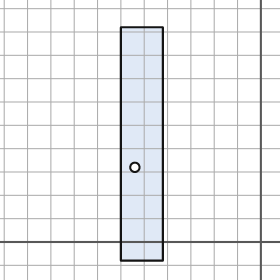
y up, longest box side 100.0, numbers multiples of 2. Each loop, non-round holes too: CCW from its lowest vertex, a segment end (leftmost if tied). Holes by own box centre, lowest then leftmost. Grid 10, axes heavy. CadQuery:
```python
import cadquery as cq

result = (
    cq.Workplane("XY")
    .moveTo(-60.0, -8.0)
    .lineTo(-42.0, -8.0)
    .lineTo(-42.0, 92.0)
    .lineTo(-60.0, 92.0)
    .close()
    .moveTo(-54.0, 32.0)
    .circle(2.0)
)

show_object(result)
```